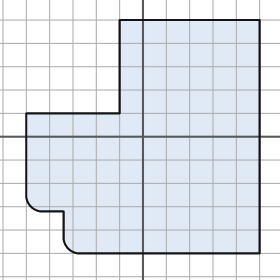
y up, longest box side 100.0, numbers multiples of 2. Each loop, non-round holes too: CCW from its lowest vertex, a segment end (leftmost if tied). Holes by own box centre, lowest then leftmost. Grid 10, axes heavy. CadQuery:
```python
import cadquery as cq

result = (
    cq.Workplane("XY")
    .moveTo(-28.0, -50.0)
    .lineTo(50.0, -50.0)
    .lineTo(50.0, 50.0)
    .lineTo(-10.0, 50.0)
    .lineTo(-10.0, 10.0)
    .lineTo(-50.0, 10.0)
    .lineTo(-50.0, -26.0)
    .threePointArc((-48.0, -30.0), (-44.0, -32.0))
    .lineTo(-34.0, -32.0)
    .lineTo(-34.0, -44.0)
    .threePointArc((-32.0, -48.0), (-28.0, -50.0))
    .close()
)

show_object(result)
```